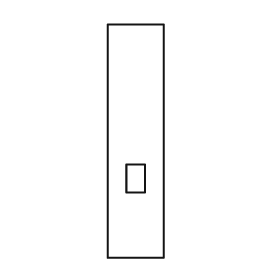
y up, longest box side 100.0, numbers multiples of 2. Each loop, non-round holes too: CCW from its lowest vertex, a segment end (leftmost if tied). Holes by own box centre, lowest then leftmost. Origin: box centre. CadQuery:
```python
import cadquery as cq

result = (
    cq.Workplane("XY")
    .moveTo(-12.0, -50.0)
    .lineTo(12.0, -50.0)
    .lineTo(12.0, 50.0)
    .lineTo(-12.0, 50.0)
    .close()
    .moveTo(-4.0, -22.0)
    .lineTo(4.0, -22.0)
    .lineTo(4.0, -10.0)
    .lineTo(-4.0, -10.0)
    .close()
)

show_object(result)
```